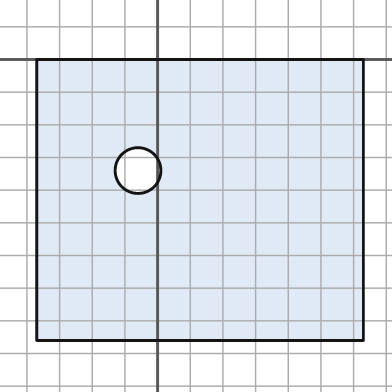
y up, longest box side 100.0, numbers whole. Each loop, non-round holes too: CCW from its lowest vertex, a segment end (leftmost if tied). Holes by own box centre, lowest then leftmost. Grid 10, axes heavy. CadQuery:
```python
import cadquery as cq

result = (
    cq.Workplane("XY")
    .moveTo(-37.0, -86.0)
    .lineTo(63.0, -86.0)
    .lineTo(63.0, 0.0)
    .lineTo(-37.0, 0.0)
    .close()
    .moveTo(-6.0, -34.0)
    .circle(7.0)
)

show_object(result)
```